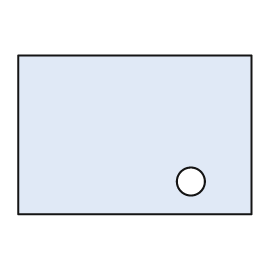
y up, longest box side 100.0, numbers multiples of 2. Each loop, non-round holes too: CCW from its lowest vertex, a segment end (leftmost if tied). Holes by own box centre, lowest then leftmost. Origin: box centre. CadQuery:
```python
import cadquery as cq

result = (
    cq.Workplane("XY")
    .moveTo(-50.0, -34.0)
    .lineTo(50.0, -34.0)
    .lineTo(50.0, 34.0)
    .lineTo(-50.0, 34.0)
    .close()
    .moveTo(24.0, -20.0)
    .circle(6.0)
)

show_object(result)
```